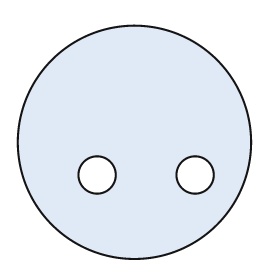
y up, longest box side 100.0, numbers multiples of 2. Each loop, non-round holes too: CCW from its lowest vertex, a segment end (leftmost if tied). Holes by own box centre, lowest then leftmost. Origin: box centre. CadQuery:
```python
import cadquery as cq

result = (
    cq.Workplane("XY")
    .moveTo(0.0, 0.0)
    .circle(50.0)
    .moveTo(-16.0, -14.0)
    .circle(8.0)
    .moveTo(26.0, -14.0)
    .circle(8.0)
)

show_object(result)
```